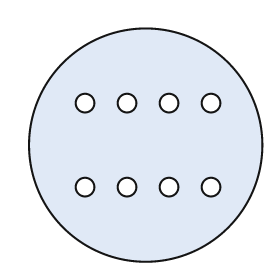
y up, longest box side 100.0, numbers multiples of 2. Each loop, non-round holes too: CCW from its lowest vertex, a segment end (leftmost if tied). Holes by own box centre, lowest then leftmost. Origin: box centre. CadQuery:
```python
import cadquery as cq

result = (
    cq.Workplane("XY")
    .moveTo(0.0, 0.0)
    .circle(50.0)
    .moveTo(-26.0, -18.0)
    .circle(4.0)
    .moveTo(-8.0, -18.0)
    .circle(4.0)
    .moveTo(10.0, -18.0)
    .circle(4.0)
    .moveTo(28.0, -18.0)
    .circle(4.0)
    .moveTo(-26.0, 18.0)
    .circle(4.0)
    .moveTo(-8.0, 18.0)
    .circle(4.0)
    .moveTo(10.0, 18.0)
    .circle(4.0)
    .moveTo(28.0, 18.0)
    .circle(4.0)
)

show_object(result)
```